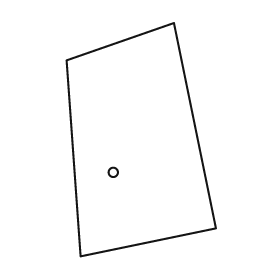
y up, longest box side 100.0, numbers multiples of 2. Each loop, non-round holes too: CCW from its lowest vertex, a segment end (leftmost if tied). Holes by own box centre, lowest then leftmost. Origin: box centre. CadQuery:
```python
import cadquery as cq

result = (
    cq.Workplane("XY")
    .moveTo(-26.0, -50.0)
    .lineTo(32.0, -38.0)
    .lineTo(14.0, 50.0)
    .lineTo(-32.0, 34.0)
    .close()
    .moveTo(-12.0, -14.0)
    .circle(2.0)
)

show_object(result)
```